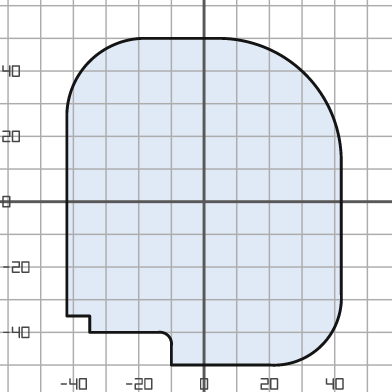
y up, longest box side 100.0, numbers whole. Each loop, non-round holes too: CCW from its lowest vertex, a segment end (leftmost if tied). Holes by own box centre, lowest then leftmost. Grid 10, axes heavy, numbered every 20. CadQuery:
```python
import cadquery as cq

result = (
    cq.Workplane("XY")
    .moveTo(-10.0, -50.0)
    .lineTo(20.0, -50.0)
    .threePointArc((36.0, -44.0), (42.0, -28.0))
    .lineTo(42.0, 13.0)
    .threePointArc((31.0, 39.0), (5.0, 50.0))
    .lineTo(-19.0, 50.0)
    .threePointArc((-35.0, 43.0), (-42.0, 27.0))
    .lineTo(-42.0, -35.0)
    .lineTo(-35.0, -35.0)
    .lineTo(-35.0, -40.0)
    .lineTo(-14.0, -40.0)
    .threePointArc((-11.0, -41.0), (-10.0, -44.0))
    .close()
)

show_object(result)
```